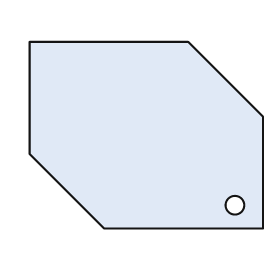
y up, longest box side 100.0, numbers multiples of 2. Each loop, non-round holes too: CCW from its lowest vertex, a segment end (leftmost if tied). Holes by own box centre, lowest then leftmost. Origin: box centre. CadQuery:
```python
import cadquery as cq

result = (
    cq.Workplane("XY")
    .moveTo(-18.0, -40.0)
    .lineTo(50.0, -40.0)
    .lineTo(50.0, 8.0)
    .lineTo(18.0, 40.0)
    .lineTo(-50.0, 40.0)
    .lineTo(-50.0, -8.0)
    .close()
    .moveTo(38.0, -30.0)
    .circle(4.0)
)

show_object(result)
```